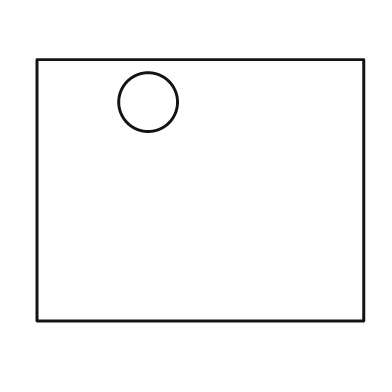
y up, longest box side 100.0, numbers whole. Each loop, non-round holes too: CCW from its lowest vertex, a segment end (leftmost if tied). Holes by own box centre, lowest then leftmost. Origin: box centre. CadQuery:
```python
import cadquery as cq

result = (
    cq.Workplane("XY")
    .moveTo(-50.0, -40.0)
    .lineTo(50.0, -40.0)
    .lineTo(50.0, 40.0)
    .lineTo(-50.0, 40.0)
    .close()
    .moveTo(-16.0, 27.0)
    .circle(9.0)
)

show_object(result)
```